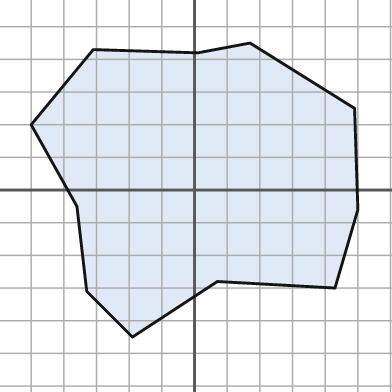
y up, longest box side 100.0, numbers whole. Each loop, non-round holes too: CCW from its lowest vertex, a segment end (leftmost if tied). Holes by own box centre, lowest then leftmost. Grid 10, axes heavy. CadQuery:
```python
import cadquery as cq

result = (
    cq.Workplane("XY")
    .moveTo(-19.0, -45.0)
    .lineTo(7.0, -28.0)
    .lineTo(43.0, -30.0)
    .lineTo(50.0, -6.0)
    .lineTo(49.0, 25.0)
    .lineTo(17.0, 45.0)
    .lineTo(1.0, 42.0)
    .lineTo(-31.0, 43.0)
    .lineTo(-50.0, 20.0)
    .lineTo(-36.0, -5.0)
    .lineTo(-33.0, -31.0)
    .close()
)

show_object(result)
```